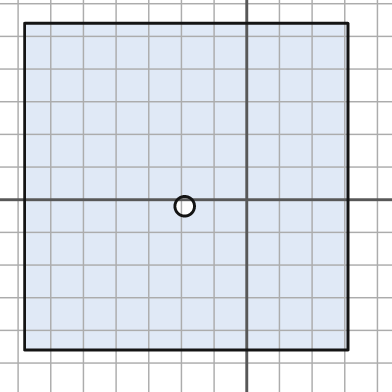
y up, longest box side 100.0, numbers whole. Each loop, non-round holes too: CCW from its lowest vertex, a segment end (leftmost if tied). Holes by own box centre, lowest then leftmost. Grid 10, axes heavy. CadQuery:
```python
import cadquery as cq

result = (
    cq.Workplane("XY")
    .moveTo(-68.0, -46.0)
    .lineTo(31.0, -46.0)
    .lineTo(31.0, 54.0)
    .lineTo(-68.0, 54.0)
    .close()
    .moveTo(-19.0, -2.0)
    .circle(3.0)
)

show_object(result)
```